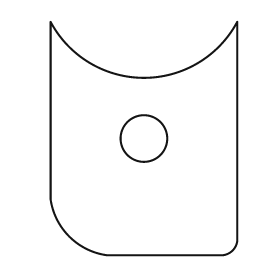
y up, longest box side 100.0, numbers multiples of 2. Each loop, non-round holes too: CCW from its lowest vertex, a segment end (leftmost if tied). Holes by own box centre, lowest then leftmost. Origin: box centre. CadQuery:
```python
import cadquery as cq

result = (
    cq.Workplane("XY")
    .moveTo(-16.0, -50.0)
    .lineTo(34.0, -50.0)
    .threePointArc((38.0, -48.0), (40.0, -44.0))
    .lineTo(40.0, 50.0)
    .threePointArc((0.0, 26.0), (-40.0, 50.0))
    .lineTo(-40.0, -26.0)
    .threePointArc((-32.0, -42.0), (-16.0, -50.0))
    .close()
    .moveTo(0.0, 0.0)
    .circle(10.0)
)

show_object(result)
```